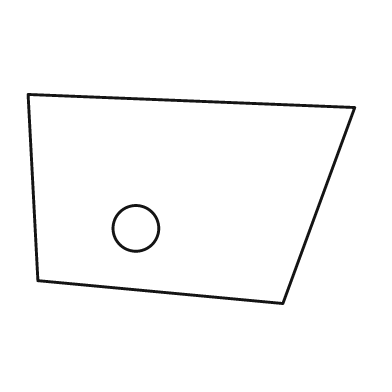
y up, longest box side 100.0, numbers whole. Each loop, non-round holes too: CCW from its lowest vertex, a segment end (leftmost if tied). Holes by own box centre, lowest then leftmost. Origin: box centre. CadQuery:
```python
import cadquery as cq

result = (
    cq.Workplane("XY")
    .moveTo(28.0, -32.0)
    .lineTo(50.0, 28.0)
    .lineTo(-50.0, 32.0)
    .lineTo(-47.0, -25.0)
    .close()
    .moveTo(-17.0, -9.0)
    .circle(7.0)
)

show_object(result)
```